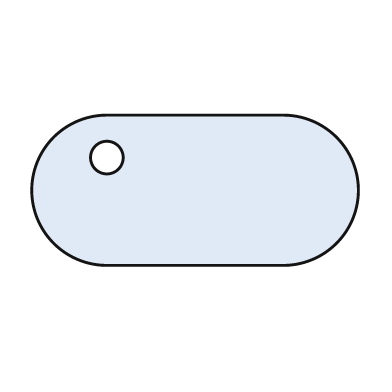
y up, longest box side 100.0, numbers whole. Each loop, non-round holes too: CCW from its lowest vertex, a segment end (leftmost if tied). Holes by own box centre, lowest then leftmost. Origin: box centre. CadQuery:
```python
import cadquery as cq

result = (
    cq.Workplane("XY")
    .moveTo(-27.0, -23.0)
    .lineTo(27.0, -23.0)
    .threePointArc((50.0, 0.0), (27.0, 23.0))
    .lineTo(-27.0, 23.0)
    .threePointArc((-50.0, 0.0), (-27.0, -23.0))
    .close()
    .moveTo(-27.0, 10.0)
    .circle(5.0)
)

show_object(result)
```